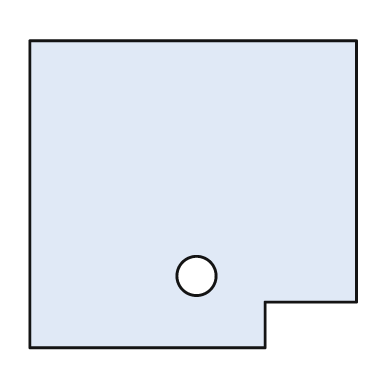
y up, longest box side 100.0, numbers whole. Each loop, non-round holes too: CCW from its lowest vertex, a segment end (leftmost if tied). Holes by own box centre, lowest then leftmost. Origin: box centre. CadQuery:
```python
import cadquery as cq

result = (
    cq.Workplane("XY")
    .moveTo(-50.0, -47.0)
    .lineTo(22.0, -47.0)
    .lineTo(22.0, -33.0)
    .lineTo(50.0, -33.0)
    .lineTo(50.0, 47.0)
    .lineTo(-50.0, 47.0)
    .close()
    .moveTo(1.0, -25.0)
    .circle(6.0)
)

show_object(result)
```